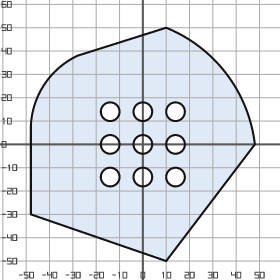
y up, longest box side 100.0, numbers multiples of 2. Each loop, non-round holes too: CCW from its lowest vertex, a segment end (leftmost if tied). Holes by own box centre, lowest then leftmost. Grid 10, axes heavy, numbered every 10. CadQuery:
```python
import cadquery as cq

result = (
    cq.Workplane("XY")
    .moveTo(10.0, -50.0)
    .lineTo(48.0, 0.0)
    .threePointArc((36.0, 30.0), (10.0, 50.0))
    .lineTo(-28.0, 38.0)
    .threePointArc((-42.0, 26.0), (-48.0, 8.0))
    .lineTo(-48.0, -30.0)
    .close()
    .moveTo(-14.0, -14.0)
    .circle(4.0)
    .moveTo(0.0, -14.0)
    .circle(4.0)
    .moveTo(14.0, -14.0)
    .circle(4.0)
    .moveTo(-14.0, 0.0)
    .circle(4.0)
    .moveTo(0.0, 0.0)
    .circle(4.0)
    .moveTo(14.0, 0.0)
    .circle(4.0)
    .moveTo(-14.0, 14.0)
    .circle(4.0)
    .moveTo(0.0, 14.0)
    .circle(4.0)
    .moveTo(14.0, 14.0)
    .circle(4.0)
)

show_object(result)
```